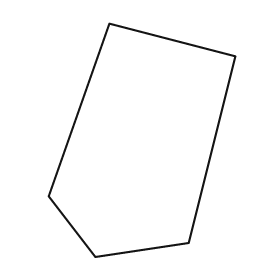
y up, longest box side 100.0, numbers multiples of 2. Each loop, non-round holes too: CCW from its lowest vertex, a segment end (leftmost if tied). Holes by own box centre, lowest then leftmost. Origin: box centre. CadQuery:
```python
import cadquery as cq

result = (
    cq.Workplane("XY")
    .moveTo(-20.0, -50.0)
    .lineTo(20.0, -44.0)
    .lineTo(40.0, 36.0)
    .lineTo(-14.0, 50.0)
    .lineTo(-40.0, -24.0)
    .close()
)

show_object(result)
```